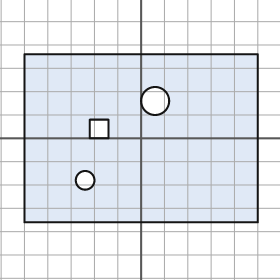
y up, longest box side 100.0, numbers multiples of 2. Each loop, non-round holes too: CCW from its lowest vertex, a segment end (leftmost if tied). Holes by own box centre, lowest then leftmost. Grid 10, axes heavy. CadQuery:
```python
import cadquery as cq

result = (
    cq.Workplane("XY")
    .moveTo(-50.0, -36.0)
    .lineTo(50.0, -36.0)
    .lineTo(50.0, 36.0)
    .lineTo(-50.0, 36.0)
    .close()
    .moveTo(-24.0, -18.0)
    .circle(4.0)
    .moveTo(-22.0, 0.0)
    .lineTo(-14.0, 0.0)
    .lineTo(-14.0, 8.0)
    .lineTo(-22.0, 8.0)
    .close()
    .moveTo(6.0, 16.0)
    .circle(6.0)
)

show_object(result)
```